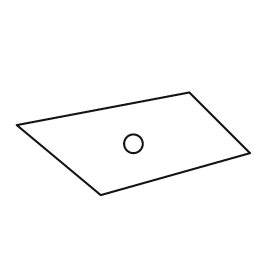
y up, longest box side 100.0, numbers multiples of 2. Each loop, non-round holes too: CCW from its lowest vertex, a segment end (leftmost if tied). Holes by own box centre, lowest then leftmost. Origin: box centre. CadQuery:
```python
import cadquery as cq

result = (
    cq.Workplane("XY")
    .moveTo(-14.0, -22.0)
    .lineTo(50.0, -4.0)
    .lineTo(24.0, 22.0)
    .lineTo(-50.0, 8.0)
    .close()
    .moveTo(0.0, 0.0)
    .circle(4.0)
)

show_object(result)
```